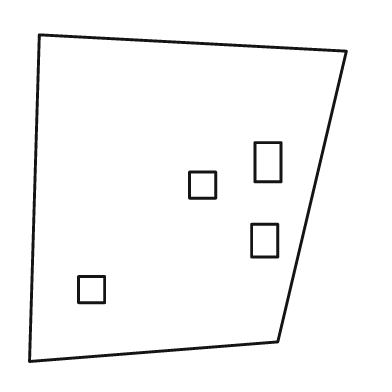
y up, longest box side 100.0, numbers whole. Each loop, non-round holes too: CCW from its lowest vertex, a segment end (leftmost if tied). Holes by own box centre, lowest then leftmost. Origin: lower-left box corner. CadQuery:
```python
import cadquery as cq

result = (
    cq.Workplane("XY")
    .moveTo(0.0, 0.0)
    .lineTo(76.0, 6.0)
    .lineTo(97.0, 95.0)
    .lineTo(3.0, 100.0)
    .close()
    .moveTo(15.0, 18.0)
    .lineTo(23.0, 18.0)
    .lineTo(23.0, 26.0)
    .lineTo(15.0, 26.0)
    .close()
    .moveTo(68.0, 32.0)
    .lineTo(76.0, 32.0)
    .lineTo(76.0, 42.0)
    .lineTo(68.0, 42.0)
    .close()
    .moveTo(49.0, 50.0)
    .lineTo(57.0, 50.0)
    .lineTo(57.0, 58.0)
    .lineTo(49.0, 58.0)
    .close()
    .moveTo(69.0, 55.0)
    .lineTo(77.0, 55.0)
    .lineTo(77.0, 67.0)
    .lineTo(69.0, 67.0)
    .close()
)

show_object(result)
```